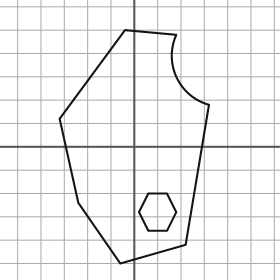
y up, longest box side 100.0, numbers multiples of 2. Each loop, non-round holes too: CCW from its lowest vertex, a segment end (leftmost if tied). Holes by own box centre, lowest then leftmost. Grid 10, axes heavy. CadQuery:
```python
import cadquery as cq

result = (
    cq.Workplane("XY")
    .moveTo(-6.0, -50.0)
    .lineTo(22.0, -42.0)
    .lineTo(32.0, 18.0)
    .threePointArc((18.0, 30.0), (18.0, 48.0))
    .lineTo(-4.0, 50.0)
    .lineTo(-32.0, 12.0)
    .lineTo(-24.0, -24.0)
    .close()
    .moveTo(6.0, -36.0)
    .lineTo(14.0, -36.0)
    .lineTo(18.0, -28.0)
    .lineTo(14.0, -20.0)
    .lineTo(6.0, -20.0)
    .lineTo(2.0, -28.0)
    .close()
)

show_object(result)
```